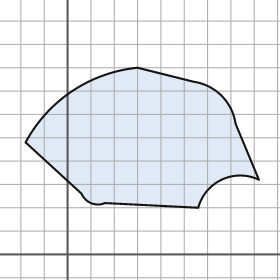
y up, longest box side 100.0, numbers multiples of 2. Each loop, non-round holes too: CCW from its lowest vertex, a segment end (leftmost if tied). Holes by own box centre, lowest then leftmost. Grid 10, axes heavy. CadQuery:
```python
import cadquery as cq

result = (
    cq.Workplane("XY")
    .moveTo(56.0, 20.0)
    .threePointArc((66.0, 32.0), (82.0, 32.0))
    .lineTo(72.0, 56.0)
    .threePointArc((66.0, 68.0), (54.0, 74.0))
    .lineTo(30.0, 80.0)
    .threePointArc((2.0, 70.0), (-18.0, 48.0))
    .lineTo(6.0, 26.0)
    .threePointArc((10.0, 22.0), (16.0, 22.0))
    .close()
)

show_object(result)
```